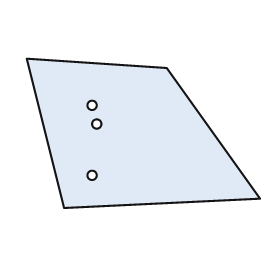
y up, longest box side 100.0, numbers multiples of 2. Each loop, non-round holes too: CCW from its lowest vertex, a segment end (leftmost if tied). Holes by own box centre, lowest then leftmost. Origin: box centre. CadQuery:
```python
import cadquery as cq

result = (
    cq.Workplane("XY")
    .moveTo(-34.0, -32.0)
    .lineTo(50.0, -28.0)
    .lineTo(10.0, 28.0)
    .lineTo(-50.0, 32.0)
    .close()
    .moveTo(-22.0, -18.0)
    .circle(2.0)
    .moveTo(-20.0, 4.0)
    .circle(2.0)
    .moveTo(-22.0, 12.0)
    .circle(2.0)
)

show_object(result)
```